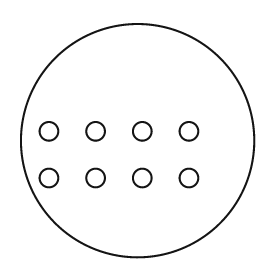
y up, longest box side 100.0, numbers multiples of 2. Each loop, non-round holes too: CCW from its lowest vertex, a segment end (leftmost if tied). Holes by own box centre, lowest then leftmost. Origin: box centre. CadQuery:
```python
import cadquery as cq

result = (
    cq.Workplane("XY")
    .moveTo(0.0, 0.0)
    .circle(50.0)
    .moveTo(-38.0, -16.0)
    .circle(4.0)
    .moveTo(-18.0, -16.0)
    .circle(4.0)
    .moveTo(2.0, -16.0)
    .circle(4.0)
    .moveTo(22.0, -16.0)
    .circle(4.0)
    .moveTo(-38.0, 4.0)
    .circle(4.0)
    .moveTo(-18.0, 4.0)
    .circle(4.0)
    .moveTo(2.0, 4.0)
    .circle(4.0)
    .moveTo(22.0, 4.0)
    .circle(4.0)
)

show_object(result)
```